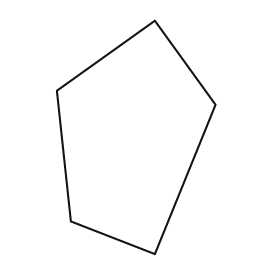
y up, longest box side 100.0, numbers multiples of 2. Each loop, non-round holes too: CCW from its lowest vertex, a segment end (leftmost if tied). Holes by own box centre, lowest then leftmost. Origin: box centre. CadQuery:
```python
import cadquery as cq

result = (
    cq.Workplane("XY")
    .moveTo(8.0, -50.0)
    .lineTo(34.0, 14.0)
    .lineTo(8.0, 50.0)
    .lineTo(-34.0, 20.0)
    .lineTo(-28.0, -36.0)
    .close()
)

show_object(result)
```